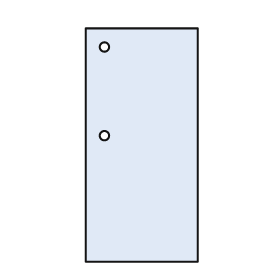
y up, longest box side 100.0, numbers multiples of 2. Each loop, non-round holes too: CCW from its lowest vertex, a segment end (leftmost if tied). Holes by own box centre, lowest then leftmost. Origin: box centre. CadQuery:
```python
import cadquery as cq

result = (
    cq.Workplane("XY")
    .moveTo(-24.0, -50.0)
    .lineTo(24.0, -50.0)
    .lineTo(24.0, 50.0)
    .lineTo(-24.0, 50.0)
    .close()
    .moveTo(-16.0, 4.0)
    .circle(2.0)
    .moveTo(-16.0, 42.0)
    .circle(2.0)
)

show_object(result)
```